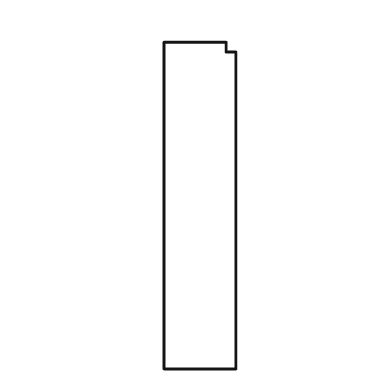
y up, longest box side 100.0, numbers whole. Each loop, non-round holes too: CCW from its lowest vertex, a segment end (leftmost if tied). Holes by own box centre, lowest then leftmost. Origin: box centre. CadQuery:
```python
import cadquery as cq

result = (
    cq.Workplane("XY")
    .moveTo(-11.0, -50.0)
    .lineTo(11.0, -50.0)
    .lineTo(11.0, 47.0)
    .lineTo(8.0, 47.0)
    .lineTo(8.0, 50.0)
    .lineTo(-11.0, 50.0)
    .close()
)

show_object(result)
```